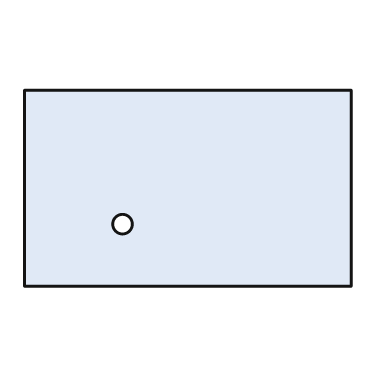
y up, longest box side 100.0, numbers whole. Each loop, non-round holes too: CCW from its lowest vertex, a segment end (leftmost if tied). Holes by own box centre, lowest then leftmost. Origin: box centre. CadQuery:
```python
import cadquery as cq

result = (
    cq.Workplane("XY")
    .moveTo(-50.0, -30.0)
    .lineTo(50.0, -30.0)
    .lineTo(50.0, 30.0)
    .lineTo(-50.0, 30.0)
    .close()
    .moveTo(-20.0, -11.0)
    .circle(3.0)
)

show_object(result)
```